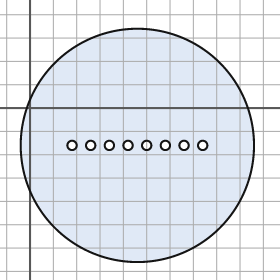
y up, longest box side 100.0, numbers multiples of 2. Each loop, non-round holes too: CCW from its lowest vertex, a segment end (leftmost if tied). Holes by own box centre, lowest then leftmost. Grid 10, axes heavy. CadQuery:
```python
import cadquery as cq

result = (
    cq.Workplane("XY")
    .moveTo(46.0, -16.0)
    .circle(50.0)
    .moveTo(18.0, -16.0)
    .circle(2.0)
    .moveTo(26.0, -16.0)
    .circle(2.0)
    .moveTo(34.0, -16.0)
    .circle(2.0)
    .moveTo(42.0, -16.0)
    .circle(2.0)
    .moveTo(50.0, -16.0)
    .circle(2.0)
    .moveTo(58.0, -16.0)
    .circle(2.0)
    .moveTo(66.0, -16.0)
    .circle(2.0)
    .moveTo(74.0, -16.0)
    .circle(2.0)
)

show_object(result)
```